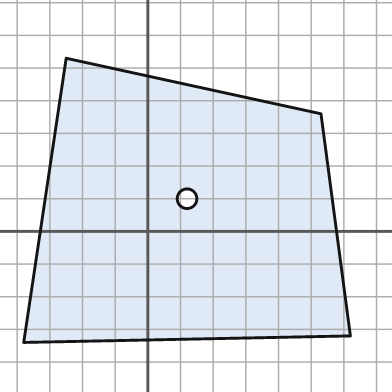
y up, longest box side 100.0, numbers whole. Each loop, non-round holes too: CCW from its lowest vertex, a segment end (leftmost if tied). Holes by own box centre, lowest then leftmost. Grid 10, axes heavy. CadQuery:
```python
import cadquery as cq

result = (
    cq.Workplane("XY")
    .moveTo(-38.0, -34.0)
    .lineTo(62.0, -32.0)
    .lineTo(53.0, 36.0)
    .lineTo(-25.0, 53.0)
    .close()
    .moveTo(12.0, 10.0)
    .circle(3.0)
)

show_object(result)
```